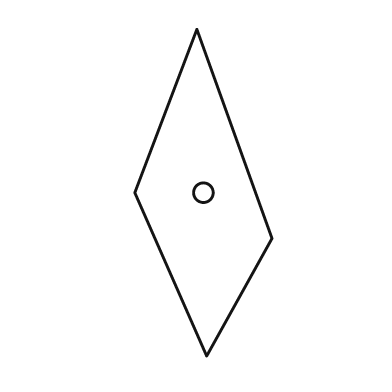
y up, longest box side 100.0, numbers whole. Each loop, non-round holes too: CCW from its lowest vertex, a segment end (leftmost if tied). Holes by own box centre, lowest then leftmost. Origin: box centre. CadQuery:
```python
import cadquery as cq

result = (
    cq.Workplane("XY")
    .moveTo(1.0, -50.0)
    .lineTo(21.0, -14.0)
    .lineTo(-2.0, 50.0)
    .lineTo(-21.0, 0.0)
    .close()
    .moveTo(0.0, 0.0)
    .circle(3.0)
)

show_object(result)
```